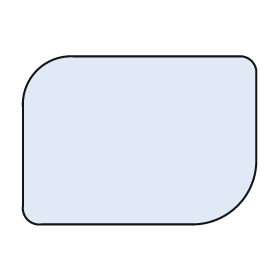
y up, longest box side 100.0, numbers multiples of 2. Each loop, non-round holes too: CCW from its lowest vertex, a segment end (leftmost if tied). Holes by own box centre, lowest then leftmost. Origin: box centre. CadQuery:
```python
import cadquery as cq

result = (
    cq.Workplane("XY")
    .moveTo(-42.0, -36.0)
    .lineTo(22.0, -36.0)
    .threePointArc((42.0, -28.0), (50.0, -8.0))
    .lineTo(50.0, 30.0)
    .threePointArc((48.0, 34.0), (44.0, 36.0))
    .lineTo(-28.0, 36.0)
    .threePointArc((-44.0, 30.0), (-50.0, 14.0))
    .lineTo(-50.0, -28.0)
    .threePointArc((-48.0, -34.0), (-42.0, -36.0))
    .close()
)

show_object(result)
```